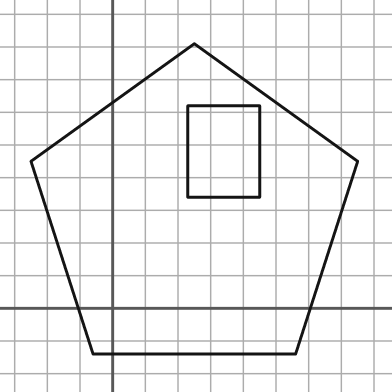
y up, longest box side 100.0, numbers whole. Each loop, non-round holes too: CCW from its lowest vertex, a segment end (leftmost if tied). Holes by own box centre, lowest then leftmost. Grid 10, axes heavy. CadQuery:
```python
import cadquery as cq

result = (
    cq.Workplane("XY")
    .moveTo(-6.0, -14.0)
    .lineTo(56.0, -14.0)
    .lineTo(75.0, 45.0)
    .lineTo(25.0, 81.0)
    .lineTo(-25.0, 45.0)
    .close()
    .moveTo(23.0, 34.0)
    .lineTo(45.0, 34.0)
    .lineTo(45.0, 62.0)
    .lineTo(23.0, 62.0)
    .close()
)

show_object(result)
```